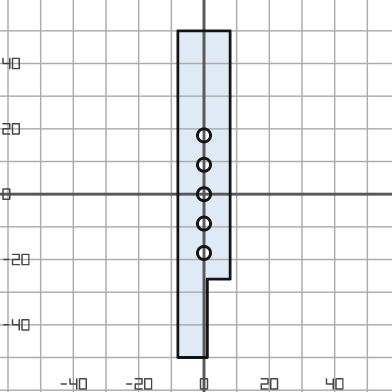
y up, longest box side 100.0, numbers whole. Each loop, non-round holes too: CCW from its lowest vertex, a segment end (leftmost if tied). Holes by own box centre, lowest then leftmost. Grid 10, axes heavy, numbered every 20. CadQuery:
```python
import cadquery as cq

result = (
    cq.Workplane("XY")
    .moveTo(-8.0, -50.0)
    .lineTo(1.0, -50.0)
    .lineTo(1.0, -26.0)
    .lineTo(8.0, -26.0)
    .lineTo(8.0, 50.0)
    .lineTo(-8.0, 50.0)
    .close()
    .moveTo(0.0, -18.0)
    .circle(2.0)
    .moveTo(0.0, -9.0)
    .circle(2.0)
    .moveTo(0.0, 0.0)
    .circle(2.0)
    .moveTo(0.0, 9.0)
    .circle(2.0)
    .moveTo(0.0, 18.0)
    .circle(2.0)
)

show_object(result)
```